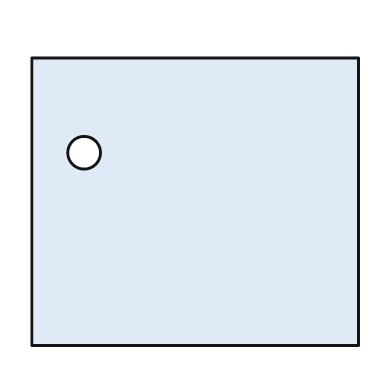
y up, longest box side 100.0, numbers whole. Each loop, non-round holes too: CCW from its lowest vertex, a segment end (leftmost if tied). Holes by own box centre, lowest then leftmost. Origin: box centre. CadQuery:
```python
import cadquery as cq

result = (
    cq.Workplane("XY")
    .moveTo(-50.0, -44.0)
    .lineTo(50.0, -44.0)
    .lineTo(50.0, 44.0)
    .lineTo(-50.0, 44.0)
    .close()
    .moveTo(-34.0, 15.0)
    .circle(5.0)
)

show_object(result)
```